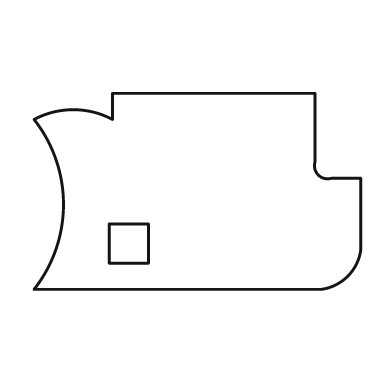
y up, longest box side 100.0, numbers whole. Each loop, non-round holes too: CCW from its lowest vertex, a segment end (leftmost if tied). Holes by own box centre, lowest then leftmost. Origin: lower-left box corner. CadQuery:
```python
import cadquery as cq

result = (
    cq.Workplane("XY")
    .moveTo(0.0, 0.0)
    .lineTo(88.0, 0.0)
    .threePointArc((96.0, 4.0), (100.0, 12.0))
    .lineTo(100.0, 34.0)
    .lineTo(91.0, 34.0)
    .threePointArc((87.0, 35.0), (86.0, 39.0))
    .lineTo(86.0, 60.0)
    .lineTo(24.0, 60.0)
    .lineTo(24.0, 52.0)
    .threePointArc((12.0, 55.0), (0.0, 52.0))
    .threePointArc((9.0, 26.0), (0.0, 0.0))
    .close()
    .moveTo(23.0, 8.0)
    .lineTo(35.0, 8.0)
    .lineTo(35.0, 20.0)
    .lineTo(23.0, 20.0)
    .close()
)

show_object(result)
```